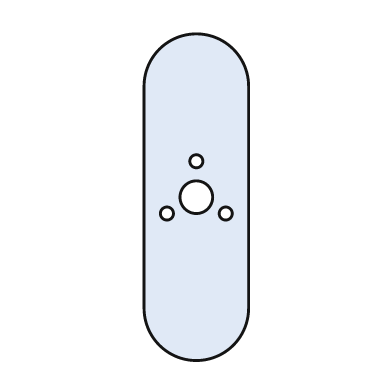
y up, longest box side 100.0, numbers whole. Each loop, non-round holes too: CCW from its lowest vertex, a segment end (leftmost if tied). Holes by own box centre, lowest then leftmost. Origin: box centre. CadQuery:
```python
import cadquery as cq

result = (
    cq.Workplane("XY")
    .moveTo(-16.0, -34.0)
    .threePointArc((0.0, -50.0), (16.0, -34.0))
    .lineTo(16.0, 34.0)
    .threePointArc((0.0, 50.0), (-16.0, 34.0))
    .close()
    .moveTo(-9.0, -5.0)
    .circle(2.0)
    .moveTo(9.0, -5.0)
    .circle(2.0)
    .moveTo(0.0, 0.0)
    .circle(5.0)
    .moveTo(0.0, 11.0)
    .circle(2.0)
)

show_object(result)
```